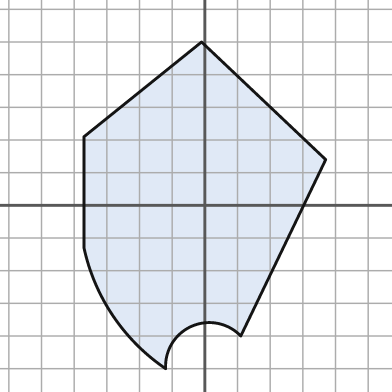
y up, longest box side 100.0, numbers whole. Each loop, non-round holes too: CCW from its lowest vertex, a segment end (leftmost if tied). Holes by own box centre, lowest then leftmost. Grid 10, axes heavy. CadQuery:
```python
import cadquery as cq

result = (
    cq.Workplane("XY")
    .moveTo(-12.0, -50.0)
    .threePointArc((-4.0, -37.0), (11.0, -40.0))
    .lineTo(37.0, 14.0)
    .lineTo(-1.0, 50.0)
    .lineTo(-37.0, 21.0)
    .lineTo(-37.0, -13.0)
    .threePointArc((-28.0, -34.0), (-12.0, -50.0))
    .close()
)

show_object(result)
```